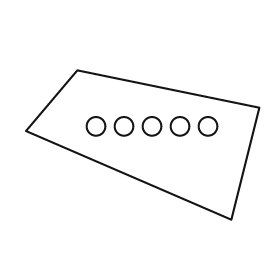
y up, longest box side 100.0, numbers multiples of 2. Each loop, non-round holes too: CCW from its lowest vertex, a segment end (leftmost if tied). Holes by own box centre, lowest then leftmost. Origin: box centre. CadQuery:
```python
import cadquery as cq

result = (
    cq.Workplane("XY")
    .moveTo(38.0, -32.0)
    .lineTo(50.0, 16.0)
    .lineTo(-28.0, 32.0)
    .lineTo(-50.0, 6.0)
    .close()
    .moveTo(-20.0, 8.0)
    .circle(4.0)
    .moveTo(-8.0, 8.0)
    .circle(4.0)
    .moveTo(4.0, 8.0)
    .circle(4.0)
    .moveTo(16.0, 8.0)
    .circle(4.0)
    .moveTo(28.0, 8.0)
    .circle(4.0)
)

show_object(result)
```